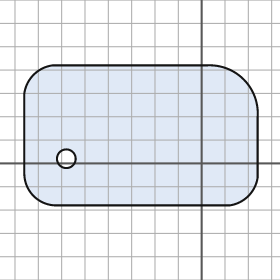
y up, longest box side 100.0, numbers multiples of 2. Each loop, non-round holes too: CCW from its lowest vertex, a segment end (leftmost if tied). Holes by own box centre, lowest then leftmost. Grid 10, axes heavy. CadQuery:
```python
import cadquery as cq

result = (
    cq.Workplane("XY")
    .moveTo(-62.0, -18.0)
    .lineTo(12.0, -18.0)
    .threePointArc((20.0, -14.0), (24.0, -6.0))
    .lineTo(24.0, 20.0)
    .threePointArc((18.0, 36.0), (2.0, 42.0))
    .lineTo(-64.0, 42.0)
    .threePointArc((-72.0, 38.0), (-76.0, 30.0))
    .lineTo(-76.0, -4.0)
    .threePointArc((-72.0, -14.0), (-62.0, -18.0))
    .close()
    .moveTo(-58.0, 2.0)
    .circle(4.0)
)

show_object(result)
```